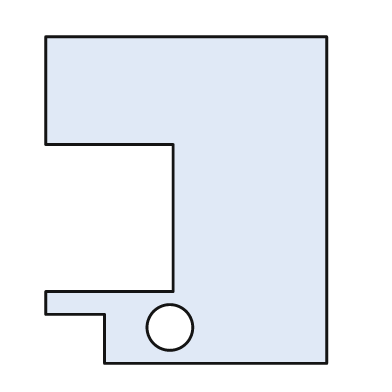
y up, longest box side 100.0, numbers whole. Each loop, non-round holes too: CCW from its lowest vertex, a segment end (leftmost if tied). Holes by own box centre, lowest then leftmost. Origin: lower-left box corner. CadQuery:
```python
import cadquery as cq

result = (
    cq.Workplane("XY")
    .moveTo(18.0, 0.0)
    .lineTo(86.0, 0.0)
    .lineTo(86.0, 100.0)
    .lineTo(0.0, 100.0)
    .lineTo(0.0, 67.0)
    .lineTo(39.0, 67.0)
    .lineTo(39.0, 22.0)
    .lineTo(0.0, 22.0)
    .lineTo(0.0, 15.0)
    .lineTo(18.0, 15.0)
    .close()
    .moveTo(38.0, 11.0)
    .circle(7.0)
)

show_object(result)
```